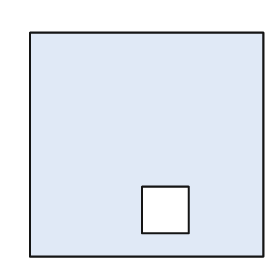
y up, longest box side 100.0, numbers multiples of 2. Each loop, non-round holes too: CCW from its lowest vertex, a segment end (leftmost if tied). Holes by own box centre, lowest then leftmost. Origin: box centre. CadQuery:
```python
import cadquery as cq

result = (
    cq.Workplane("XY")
    .moveTo(-50.0, -48.0)
    .lineTo(50.0, -48.0)
    .lineTo(50.0, 48.0)
    .lineTo(-50.0, 48.0)
    .close()
    .moveTo(-2.0, -38.0)
    .lineTo(18.0, -38.0)
    .lineTo(18.0, -18.0)
    .lineTo(-2.0, -18.0)
    .close()
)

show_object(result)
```